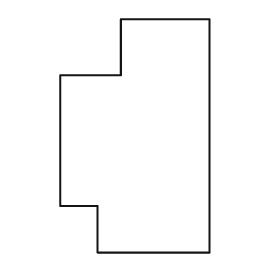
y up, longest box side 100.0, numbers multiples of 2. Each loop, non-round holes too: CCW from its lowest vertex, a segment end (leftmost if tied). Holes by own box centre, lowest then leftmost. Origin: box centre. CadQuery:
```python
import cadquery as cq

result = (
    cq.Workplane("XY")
    .moveTo(-16.0, -50.0)
    .lineTo(32.0, -50.0)
    .lineTo(32.0, 50.0)
    .lineTo(-6.0, 50.0)
    .lineTo(-6.0, 26.0)
    .lineTo(-32.0, 26.0)
    .lineTo(-32.0, -30.0)
    .lineTo(-16.0, -30.0)
    .close()
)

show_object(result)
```